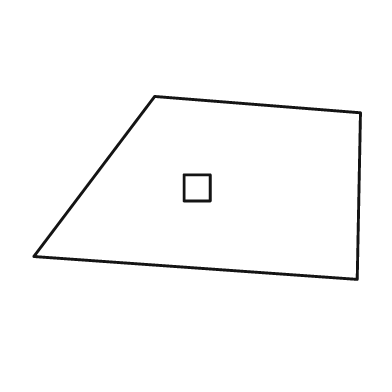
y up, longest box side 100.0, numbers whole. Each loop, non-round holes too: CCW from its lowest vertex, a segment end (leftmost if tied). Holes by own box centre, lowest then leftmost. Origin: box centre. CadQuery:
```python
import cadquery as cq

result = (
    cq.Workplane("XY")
    .moveTo(49.0, -28.0)
    .lineTo(50.0, 23.0)
    .lineTo(-13.0, 28.0)
    .lineTo(-50.0, -21.0)
    .close()
    .moveTo(-4.0, -4.0)
    .lineTo(4.0, -4.0)
    .lineTo(4.0, 4.0)
    .lineTo(-4.0, 4.0)
    .close()
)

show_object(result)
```